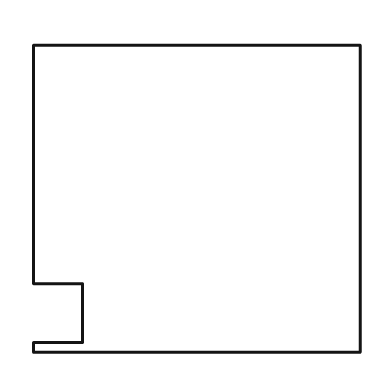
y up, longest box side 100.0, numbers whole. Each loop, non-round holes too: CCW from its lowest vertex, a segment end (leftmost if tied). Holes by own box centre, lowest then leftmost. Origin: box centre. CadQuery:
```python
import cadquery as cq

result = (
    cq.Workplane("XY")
    .moveTo(-50.0, -47.0)
    .lineTo(50.0, -47.0)
    .lineTo(50.0, 47.0)
    .lineTo(-50.0, 47.0)
    .lineTo(-50.0, -26.0)
    .lineTo(-35.0, -26.0)
    .lineTo(-35.0, -44.0)
    .lineTo(-50.0, -44.0)
    .close()
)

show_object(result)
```